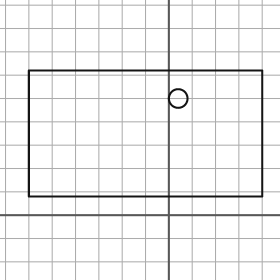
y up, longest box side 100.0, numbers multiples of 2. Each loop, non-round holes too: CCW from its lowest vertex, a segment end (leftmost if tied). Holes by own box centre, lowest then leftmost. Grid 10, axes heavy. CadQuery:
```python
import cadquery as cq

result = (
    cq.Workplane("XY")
    .moveTo(-60.0, 8.0)
    .lineTo(40.0, 8.0)
    .lineTo(40.0, 62.0)
    .lineTo(-60.0, 62.0)
    .close()
    .moveTo(4.0, 50.0)
    .circle(4.0)
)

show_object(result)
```